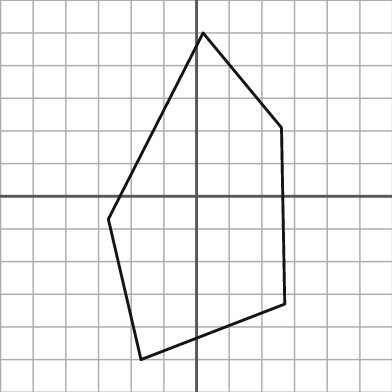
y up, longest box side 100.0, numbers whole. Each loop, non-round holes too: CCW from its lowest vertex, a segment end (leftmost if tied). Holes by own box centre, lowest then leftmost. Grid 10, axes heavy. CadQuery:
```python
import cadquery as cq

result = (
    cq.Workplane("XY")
    .moveTo(-17.0, -50.0)
    .lineTo(27.0, -33.0)
    .lineTo(26.0, 21.0)
    .lineTo(2.0, 50.0)
    .lineTo(-27.0, -7.0)
    .close()
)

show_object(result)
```